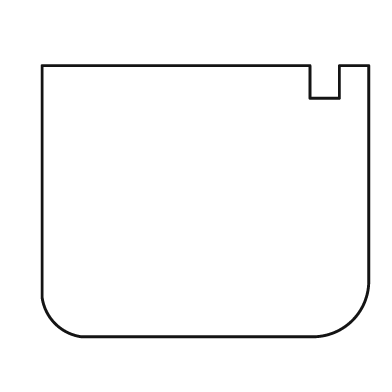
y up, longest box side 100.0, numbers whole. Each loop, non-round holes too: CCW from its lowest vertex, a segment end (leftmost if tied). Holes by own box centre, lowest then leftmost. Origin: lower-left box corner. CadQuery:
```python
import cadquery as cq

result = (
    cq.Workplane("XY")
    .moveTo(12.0, 0.0)
    .lineTo(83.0, 0.0)
    .threePointArc((95.0, 5.0), (100.0, 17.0))
    .lineTo(100.0, 83.0)
    .lineTo(91.0, 83.0)
    .lineTo(91.0, 73.0)
    .lineTo(82.0, 73.0)
    .lineTo(82.0, 83.0)
    .lineTo(0.0, 83.0)
    .lineTo(0.0, 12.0)
    .threePointArc((4.0, 4.0), (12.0, 0.0))
    .close()
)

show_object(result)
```